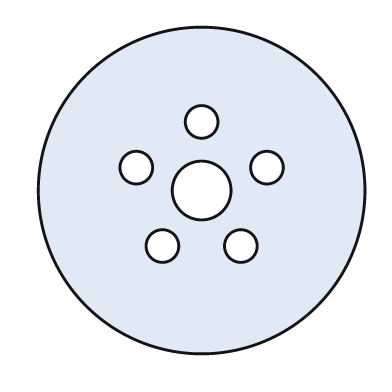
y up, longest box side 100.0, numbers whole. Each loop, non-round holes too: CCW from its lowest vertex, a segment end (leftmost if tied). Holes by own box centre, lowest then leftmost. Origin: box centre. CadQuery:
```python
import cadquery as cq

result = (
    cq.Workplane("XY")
    .moveTo(0.0, 0.0)
    .circle(50.0)
    .moveTo(-12.0, -17.0)
    .circle(5.0)
    .moveTo(12.0, -17.0)
    .circle(5.0)
    .moveTo(0.0, 0.0)
    .circle(9.0)
    .moveTo(-20.0, 7.0)
    .circle(5.0)
    .moveTo(20.0, 7.0)
    .circle(5.0)
    .moveTo(0.0, 21.0)
    .circle(5.0)
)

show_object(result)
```